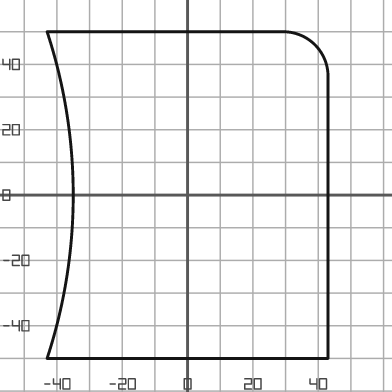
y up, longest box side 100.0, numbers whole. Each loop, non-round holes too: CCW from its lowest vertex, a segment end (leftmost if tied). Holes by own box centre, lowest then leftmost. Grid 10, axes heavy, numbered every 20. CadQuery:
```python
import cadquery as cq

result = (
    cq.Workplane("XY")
    .moveTo(-43.0, -50.0)
    .lineTo(43.0, -50.0)
    .lineTo(43.0, 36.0)
    .threePointArc((39.0, 46.0), (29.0, 50.0))
    .lineTo(-43.0, 50.0)
    .threePointArc((-35.0, 0.0), (-43.0, -50.0))
    .close()
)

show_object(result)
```